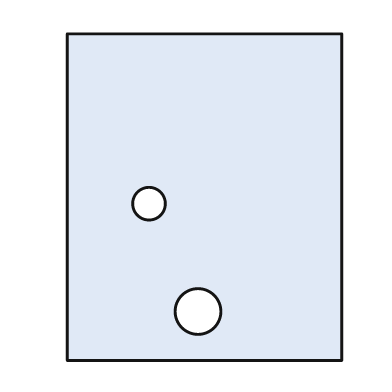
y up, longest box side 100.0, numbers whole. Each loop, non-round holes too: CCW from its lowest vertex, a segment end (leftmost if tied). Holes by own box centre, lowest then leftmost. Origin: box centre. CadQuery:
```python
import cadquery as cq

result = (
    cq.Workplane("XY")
    .moveTo(-42.0, -50.0)
    .lineTo(42.0, -50.0)
    .lineTo(42.0, 50.0)
    .lineTo(-42.0, 50.0)
    .close()
    .moveTo(-2.0, -35.0)
    .circle(7.0)
    .moveTo(-17.0, -2.0)
    .circle(5.0)
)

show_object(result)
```